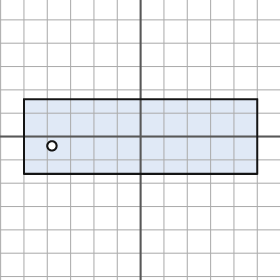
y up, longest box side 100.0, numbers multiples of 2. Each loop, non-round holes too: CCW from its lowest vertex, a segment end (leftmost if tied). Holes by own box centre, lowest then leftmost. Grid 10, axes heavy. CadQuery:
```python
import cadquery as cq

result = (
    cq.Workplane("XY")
    .moveTo(-50.0, -16.0)
    .lineTo(50.0, -16.0)
    .lineTo(50.0, 16.0)
    .lineTo(-50.0, 16.0)
    .close()
    .moveTo(-38.0, -4.0)
    .circle(2.0)
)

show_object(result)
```